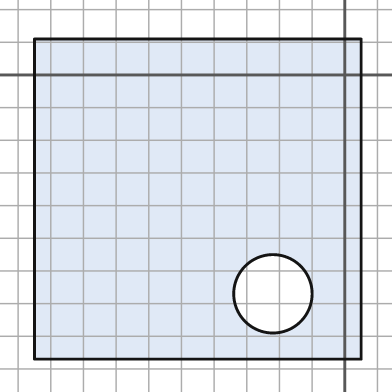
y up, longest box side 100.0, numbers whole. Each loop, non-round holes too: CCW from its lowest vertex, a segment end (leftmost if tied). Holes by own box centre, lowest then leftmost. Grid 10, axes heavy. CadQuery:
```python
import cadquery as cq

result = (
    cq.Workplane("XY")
    .moveTo(-95.0, -87.0)
    .lineTo(5.0, -87.0)
    .lineTo(5.0, 11.0)
    .lineTo(-95.0, 11.0)
    .close()
    .moveTo(-22.0, -67.0)
    .circle(12.0)
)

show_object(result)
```